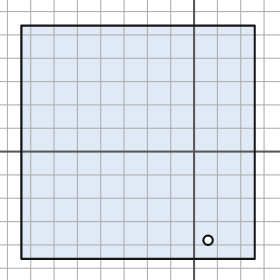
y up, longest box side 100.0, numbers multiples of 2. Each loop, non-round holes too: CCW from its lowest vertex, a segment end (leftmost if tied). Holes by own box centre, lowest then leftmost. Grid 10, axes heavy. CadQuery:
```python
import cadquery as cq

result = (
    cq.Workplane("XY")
    .moveTo(-74.0, -46.0)
    .lineTo(26.0, -46.0)
    .lineTo(26.0, 54.0)
    .lineTo(-74.0, 54.0)
    .close()
    .moveTo(6.0, -38.0)
    .circle(2.0)
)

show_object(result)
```